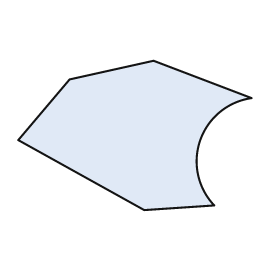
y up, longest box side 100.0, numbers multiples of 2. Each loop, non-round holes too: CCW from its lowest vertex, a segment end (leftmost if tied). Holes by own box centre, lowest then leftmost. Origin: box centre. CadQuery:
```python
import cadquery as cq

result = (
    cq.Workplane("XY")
    .moveTo(4.0, -32.0)
    .lineTo(34.0, -30.0)
    .threePointArc((28.0, -2.0), (50.0, 16.0))
    .lineTo(8.0, 32.0)
    .lineTo(-28.0, 24.0)
    .lineTo(-50.0, -2.0)
    .close()
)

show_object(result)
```